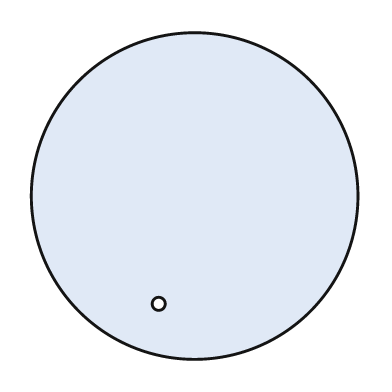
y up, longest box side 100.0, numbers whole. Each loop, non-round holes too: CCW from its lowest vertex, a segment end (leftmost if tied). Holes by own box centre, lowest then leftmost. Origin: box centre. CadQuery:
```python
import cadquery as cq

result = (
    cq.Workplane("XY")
    .moveTo(0.0, 0.0)
    .circle(50.0)
    .moveTo(-11.0, -33.0)
    .circle(2.0)
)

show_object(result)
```